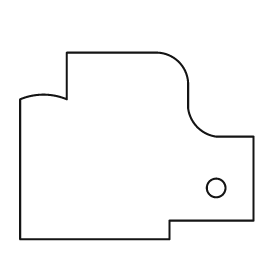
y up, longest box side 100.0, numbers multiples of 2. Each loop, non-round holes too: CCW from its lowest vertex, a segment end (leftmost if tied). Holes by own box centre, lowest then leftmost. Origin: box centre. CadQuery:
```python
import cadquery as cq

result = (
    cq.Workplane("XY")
    .moveTo(-50.0, -40.0)
    .lineTo(14.0, -40.0)
    .lineTo(14.0, -32.0)
    .lineTo(50.0, -32.0)
    .lineTo(50.0, 4.0)
    .lineTo(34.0, 4.0)
    .threePointArc((26.0, 8.0), (22.0, 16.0))
    .lineTo(22.0, 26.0)
    .threePointArc((18.0, 36.0), (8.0, 40.0))
    .lineTo(-30.0, 40.0)
    .lineTo(-30.0, 20.0)
    .threePointArc((-40.0, 22.0), (-50.0, 20.0))
    .close()
    .moveTo(34.0, -18.0)
    .circle(4.0)
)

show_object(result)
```